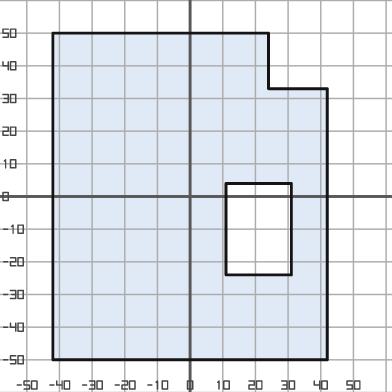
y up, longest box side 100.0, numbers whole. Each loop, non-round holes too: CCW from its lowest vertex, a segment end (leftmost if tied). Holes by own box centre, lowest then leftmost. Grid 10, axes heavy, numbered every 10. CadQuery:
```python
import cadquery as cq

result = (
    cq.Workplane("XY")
    .moveTo(-42.0, -50.0)
    .lineTo(42.0, -50.0)
    .lineTo(42.0, 33.0)
    .lineTo(24.0, 33.0)
    .lineTo(24.0, 50.0)
    .lineTo(-42.0, 50.0)
    .close()
    .moveTo(11.0, -24.0)
    .lineTo(31.0, -24.0)
    .lineTo(31.0, 4.0)
    .lineTo(11.0, 4.0)
    .close()
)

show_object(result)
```